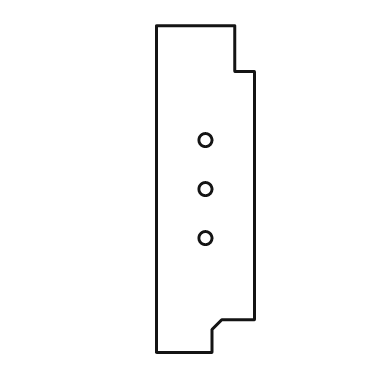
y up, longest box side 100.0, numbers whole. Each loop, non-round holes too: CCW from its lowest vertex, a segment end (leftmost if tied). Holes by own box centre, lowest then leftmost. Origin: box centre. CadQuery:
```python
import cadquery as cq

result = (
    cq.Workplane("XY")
    .moveTo(-15.0, -50.0)
    .lineTo(2.0, -50.0)
    .lineTo(2.0, -43.0)
    .lineTo(5.0, -40.0)
    .lineTo(15.0, -40.0)
    .lineTo(15.0, 36.0)
    .lineTo(9.0, 36.0)
    .lineTo(9.0, 50.0)
    .lineTo(-15.0, 50.0)
    .close()
    .moveTo(0.0, -15.0)
    .circle(2.0)
    .moveTo(0.0, 0.0)
    .circle(2.0)
    .moveTo(0.0, 15.0)
    .circle(2.0)
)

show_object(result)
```